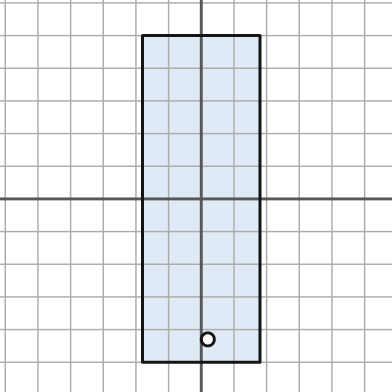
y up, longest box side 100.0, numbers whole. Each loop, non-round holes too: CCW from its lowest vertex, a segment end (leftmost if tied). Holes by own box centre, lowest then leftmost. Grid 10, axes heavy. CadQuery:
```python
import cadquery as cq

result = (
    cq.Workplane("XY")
    .moveTo(-18.0, -50.0)
    .lineTo(18.0, -50.0)
    .lineTo(18.0, 50.0)
    .lineTo(-18.0, 50.0)
    .close()
    .moveTo(2.0, -43.0)
    .circle(2.0)
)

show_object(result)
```